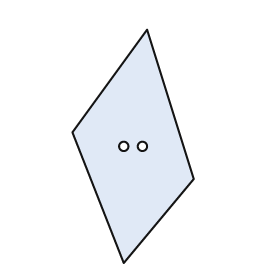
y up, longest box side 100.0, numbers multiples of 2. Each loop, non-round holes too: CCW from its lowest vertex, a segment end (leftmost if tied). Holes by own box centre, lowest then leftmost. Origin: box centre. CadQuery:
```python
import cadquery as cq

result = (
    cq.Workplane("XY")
    .moveTo(-4.0, -50.0)
    .lineTo(26.0, -14.0)
    .lineTo(6.0, 50.0)
    .lineTo(-26.0, 6.0)
    .close()
    .moveTo(-4.0, 0.0)
    .circle(2.0)
    .moveTo(4.0, 0.0)
    .circle(2.0)
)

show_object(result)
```